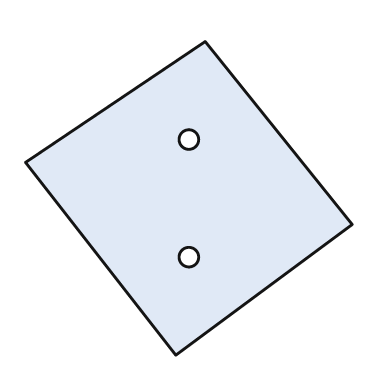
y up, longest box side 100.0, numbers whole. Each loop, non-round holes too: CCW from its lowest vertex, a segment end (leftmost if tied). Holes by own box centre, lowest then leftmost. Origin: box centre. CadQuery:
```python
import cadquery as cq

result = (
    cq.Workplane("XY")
    .moveTo(-4.0, -48.0)
    .lineTo(50.0, -8.0)
    .lineTo(5.0, 48.0)
    .lineTo(-50.0, 11.0)
    .close()
    .moveTo(0.0, -18.0)
    .circle(3.0)
    .moveTo(0.0, 18.0)
    .circle(3.0)
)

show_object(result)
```